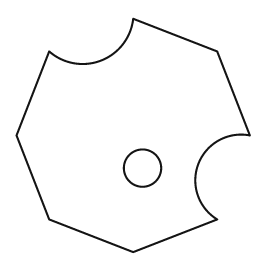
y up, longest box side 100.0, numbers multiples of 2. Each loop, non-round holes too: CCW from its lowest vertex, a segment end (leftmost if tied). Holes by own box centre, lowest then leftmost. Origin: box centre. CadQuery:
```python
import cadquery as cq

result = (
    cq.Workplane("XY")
    .moveTo(0.0, -50.0)
    .lineTo(36.0, -36.0)
    .threePointArc((28.0, -12.0), (50.0, 0.0))
    .lineTo(36.0, 36.0)
    .lineTo(0.0, 50.0)
    .threePointArc((-14.0, 32.0), (-36.0, 36.0))
    .lineTo(-50.0, 0.0)
    .lineTo(-36.0, -36.0)
    .close()
    .moveTo(4.0, -14.0)
    .circle(8.0)
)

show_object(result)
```